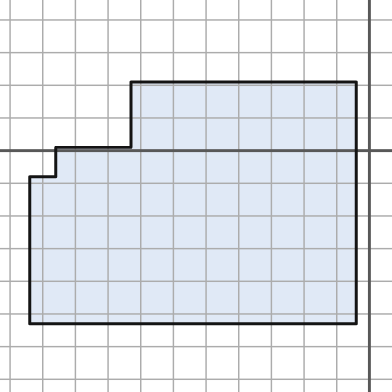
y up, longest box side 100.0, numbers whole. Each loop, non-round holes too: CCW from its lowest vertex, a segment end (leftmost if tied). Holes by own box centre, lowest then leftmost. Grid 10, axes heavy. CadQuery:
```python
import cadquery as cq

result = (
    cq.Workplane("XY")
    .moveTo(-104.0, -53.0)
    .lineTo(-4.0, -53.0)
    .lineTo(-4.0, 21.0)
    .lineTo(-73.0, 21.0)
    .lineTo(-73.0, 1.0)
    .lineTo(-96.0, 1.0)
    .lineTo(-96.0, -8.0)
    .lineTo(-104.0, -8.0)
    .close()
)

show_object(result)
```